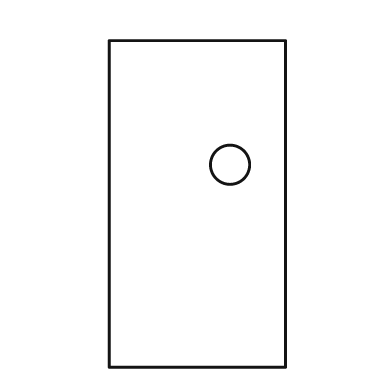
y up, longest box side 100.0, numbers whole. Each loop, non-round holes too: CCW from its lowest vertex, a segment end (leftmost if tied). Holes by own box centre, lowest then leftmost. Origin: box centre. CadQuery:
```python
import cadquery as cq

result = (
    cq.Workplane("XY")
    .moveTo(-27.0, -50.0)
    .lineTo(27.0, -50.0)
    .lineTo(27.0, 50.0)
    .lineTo(-27.0, 50.0)
    .close()
    .moveTo(10.0, 12.0)
    .circle(6.0)
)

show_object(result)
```